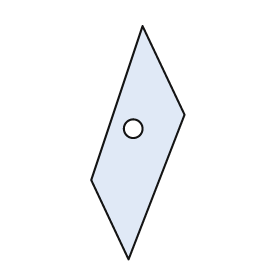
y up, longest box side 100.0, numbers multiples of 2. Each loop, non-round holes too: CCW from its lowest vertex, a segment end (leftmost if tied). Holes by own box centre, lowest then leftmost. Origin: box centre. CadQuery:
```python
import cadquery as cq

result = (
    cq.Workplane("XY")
    .moveTo(-4.0, -50.0)
    .lineTo(20.0, 12.0)
    .lineTo(2.0, 50.0)
    .lineTo(-20.0, -16.0)
    .close()
    .moveTo(-2.0, 6.0)
    .circle(4.0)
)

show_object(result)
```